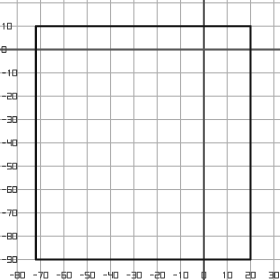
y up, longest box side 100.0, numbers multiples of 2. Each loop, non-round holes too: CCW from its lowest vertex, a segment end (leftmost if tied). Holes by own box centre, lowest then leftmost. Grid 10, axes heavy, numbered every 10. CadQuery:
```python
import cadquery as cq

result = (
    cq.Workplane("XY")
    .moveTo(-72.0, -90.0)
    .lineTo(20.0, -90.0)
    .lineTo(20.0, 10.0)
    .lineTo(-72.0, 10.0)
    .close()
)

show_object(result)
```